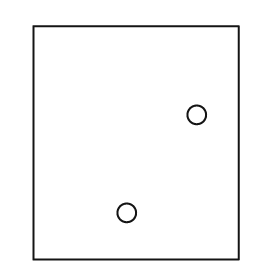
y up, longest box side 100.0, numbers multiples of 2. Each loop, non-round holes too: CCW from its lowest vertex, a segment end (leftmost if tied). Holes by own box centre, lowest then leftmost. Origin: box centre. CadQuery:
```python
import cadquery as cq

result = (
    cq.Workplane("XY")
    .moveTo(-44.0, -50.0)
    .lineTo(44.0, -50.0)
    .lineTo(44.0, 50.0)
    .lineTo(-44.0, 50.0)
    .close()
    .moveTo(-4.0, -30.0)
    .circle(4.0)
    .moveTo(26.0, 12.0)
    .circle(4.0)
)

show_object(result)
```